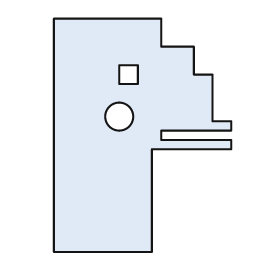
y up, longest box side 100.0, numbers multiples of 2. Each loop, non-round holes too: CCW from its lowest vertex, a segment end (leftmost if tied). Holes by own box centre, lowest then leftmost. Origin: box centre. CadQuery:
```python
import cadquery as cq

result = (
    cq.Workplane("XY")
    .moveTo(-38.0, -50.0)
    .lineTo(4.0, -50.0)
    .lineTo(4.0, -6.0)
    .lineTo(38.0, -6.0)
    .lineTo(38.0, -2.0)
    .lineTo(8.0, -2.0)
    .lineTo(8.0, 2.0)
    .lineTo(38.0, 2.0)
    .lineTo(38.0, 6.0)
    .lineTo(30.0, 6.0)
    .lineTo(30.0, 26.0)
    .lineTo(22.0, 26.0)
    .lineTo(22.0, 38.0)
    .lineTo(8.0, 38.0)
    .lineTo(8.0, 50.0)
    .lineTo(-38.0, 50.0)
    .close()
    .moveTo(-10.0, 8.0)
    .circle(6.0)
    .moveTo(-10.0, 22.0)
    .lineTo(-2.0, 22.0)
    .lineTo(-2.0, 30.0)
    .lineTo(-10.0, 30.0)
    .close()
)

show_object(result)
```